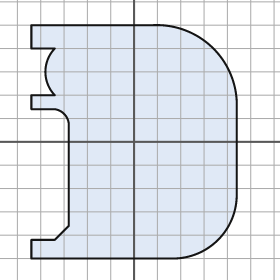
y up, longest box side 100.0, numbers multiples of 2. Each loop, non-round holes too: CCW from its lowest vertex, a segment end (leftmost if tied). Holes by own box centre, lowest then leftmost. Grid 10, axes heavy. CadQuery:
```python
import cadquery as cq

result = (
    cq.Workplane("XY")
    .moveTo(-44.0, -50.0)
    .lineTo(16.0, -50.0)
    .threePointArc((36.0, -42.0), (44.0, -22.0))
    .lineTo(44.0, 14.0)
    .threePointArc((34.0, 40.0), (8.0, 50.0))
    .lineTo(-44.0, 50.0)
    .lineTo(-44.0, 40.0)
    .lineTo(-34.0, 40.0)
    .threePointArc((-38.0, 30.0), (-34.0, 20.0))
    .lineTo(-44.0, 20.0)
    .lineTo(-44.0, 14.0)
    .lineTo(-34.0, 14.0)
    .threePointArc((-30.0, 12.0), (-28.0, 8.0))
    .lineTo(-28.0, -36.0)
    .lineTo(-34.0, -42.0)
    .lineTo(-44.0, -42.0)
    .close()
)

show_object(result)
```